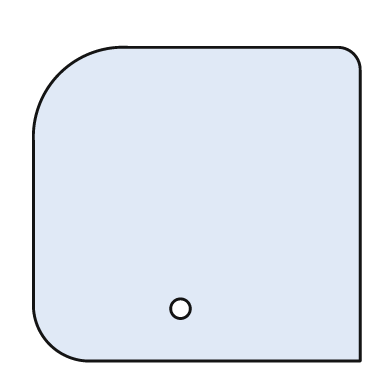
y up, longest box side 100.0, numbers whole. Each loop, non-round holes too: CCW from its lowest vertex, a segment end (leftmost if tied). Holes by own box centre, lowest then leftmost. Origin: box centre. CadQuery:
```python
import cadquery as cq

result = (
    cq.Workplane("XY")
    .moveTo(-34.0, -48.0)
    .lineTo(50.0, -48.0)
    .lineTo(50.0, 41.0)
    .threePointArc((48.0, 46.0), (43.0, 48.0))
    .lineTo(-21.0, 48.0)
    .threePointArc((-42.0, 40.0), (-50.0, 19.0))
    .lineTo(-50.0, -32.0)
    .threePointArc((-45.0, -43.0), (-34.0, -48.0))
    .close()
    .moveTo(-5.0, -32.0)
    .circle(3.0)
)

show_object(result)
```